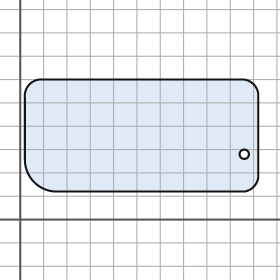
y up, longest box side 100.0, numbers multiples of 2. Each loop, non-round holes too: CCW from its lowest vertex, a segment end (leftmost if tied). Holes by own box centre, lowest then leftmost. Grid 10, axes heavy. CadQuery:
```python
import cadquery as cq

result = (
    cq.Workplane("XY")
    .moveTo(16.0, 12.0)
    .lineTo(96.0, 12.0)
    .threePointArc((100.0, 14.0), (102.0, 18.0))
    .lineTo(102.0, 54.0)
    .threePointArc((100.0, 58.0), (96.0, 60.0))
    .lineTo(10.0, 60.0)
    .threePointArc((4.0, 58.0), (2.0, 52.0))
    .lineTo(2.0, 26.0)
    .threePointArc((6.0, 16.0), (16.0, 12.0))
    .close()
    .moveTo(96.0, 28.0)
    .circle(2.0)
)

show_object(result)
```